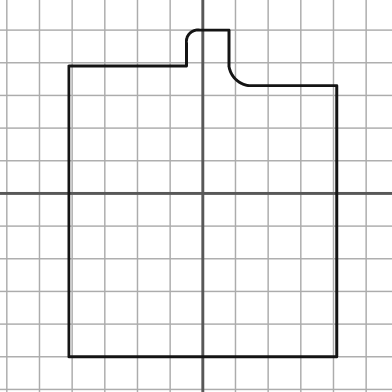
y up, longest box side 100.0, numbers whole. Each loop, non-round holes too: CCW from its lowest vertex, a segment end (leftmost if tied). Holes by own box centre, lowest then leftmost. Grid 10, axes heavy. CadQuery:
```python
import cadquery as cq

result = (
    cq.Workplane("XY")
    .moveTo(-41.0, -50.0)
    .lineTo(41.0, -50.0)
    .lineTo(41.0, 33.0)
    .lineTo(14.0, 33.0)
    .threePointArc((10.0, 35.0), (8.0, 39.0))
    .lineTo(8.0, 50.0)
    .lineTo(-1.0, 50.0)
    .threePointArc((-4.0, 49.0), (-5.0, 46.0))
    .lineTo(-5.0, 39.0)
    .lineTo(-41.0, 39.0)
    .close()
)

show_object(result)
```